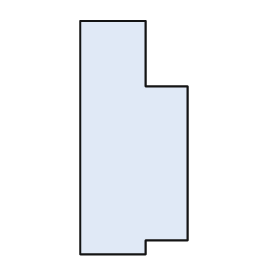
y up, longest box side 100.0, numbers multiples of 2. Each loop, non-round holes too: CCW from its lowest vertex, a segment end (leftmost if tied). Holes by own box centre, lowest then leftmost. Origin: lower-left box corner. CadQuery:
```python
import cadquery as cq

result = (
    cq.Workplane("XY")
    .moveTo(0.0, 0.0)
    .lineTo(28.0, 0.0)
    .lineTo(28.0, 6.0)
    .lineTo(46.0, 6.0)
    .lineTo(46.0, 72.0)
    .lineTo(28.0, 72.0)
    .lineTo(28.0, 100.0)
    .lineTo(0.0, 100.0)
    .close()
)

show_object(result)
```